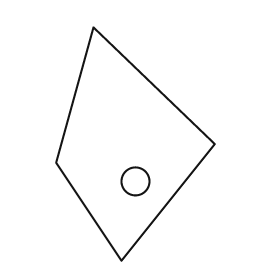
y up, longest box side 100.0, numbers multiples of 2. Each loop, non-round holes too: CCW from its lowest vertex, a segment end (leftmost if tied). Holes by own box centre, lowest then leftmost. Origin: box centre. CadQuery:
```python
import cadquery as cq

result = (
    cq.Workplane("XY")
    .moveTo(-6.0, -50.0)
    .lineTo(34.0, 0.0)
    .lineTo(-18.0, 50.0)
    .lineTo(-34.0, -8.0)
    .close()
    .moveTo(0.0, -16.0)
    .circle(6.0)
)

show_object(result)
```